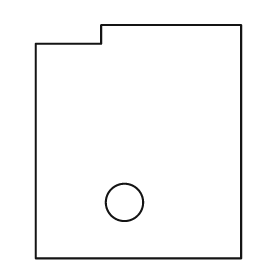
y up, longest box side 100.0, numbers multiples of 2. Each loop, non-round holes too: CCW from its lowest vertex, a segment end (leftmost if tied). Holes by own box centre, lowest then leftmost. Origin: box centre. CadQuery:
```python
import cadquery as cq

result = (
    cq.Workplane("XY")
    .moveTo(-44.0, -50.0)
    .lineTo(44.0, -50.0)
    .lineTo(44.0, 50.0)
    .lineTo(-16.0, 50.0)
    .lineTo(-16.0, 42.0)
    .lineTo(-44.0, 42.0)
    .close()
    .moveTo(-6.0, -26.0)
    .circle(8.0)
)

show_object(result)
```